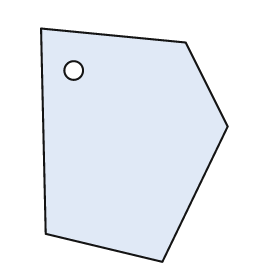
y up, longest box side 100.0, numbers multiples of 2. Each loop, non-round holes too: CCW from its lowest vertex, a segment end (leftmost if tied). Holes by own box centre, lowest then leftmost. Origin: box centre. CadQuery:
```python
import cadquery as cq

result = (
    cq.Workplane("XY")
    .moveTo(12.0, -50.0)
    .lineTo(40.0, 8.0)
    .lineTo(22.0, 44.0)
    .lineTo(-40.0, 50.0)
    .lineTo(-38.0, -38.0)
    .close()
    .moveTo(-26.0, 32.0)
    .circle(4.0)
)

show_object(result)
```